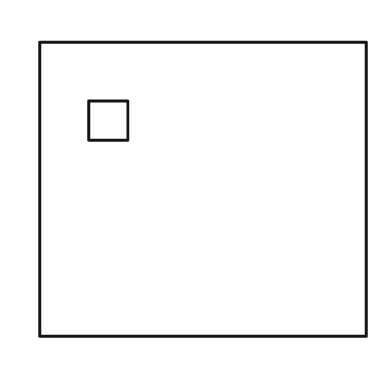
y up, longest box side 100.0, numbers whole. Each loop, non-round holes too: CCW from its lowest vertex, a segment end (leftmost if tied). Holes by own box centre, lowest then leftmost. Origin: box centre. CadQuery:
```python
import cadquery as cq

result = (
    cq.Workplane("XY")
    .moveTo(-50.0, -45.0)
    .lineTo(50.0, -45.0)
    .lineTo(50.0, 45.0)
    .lineTo(-50.0, 45.0)
    .close()
    .moveTo(-35.0, 15.0)
    .lineTo(-23.0, 15.0)
    .lineTo(-23.0, 27.0)
    .lineTo(-35.0, 27.0)
    .close()
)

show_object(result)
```